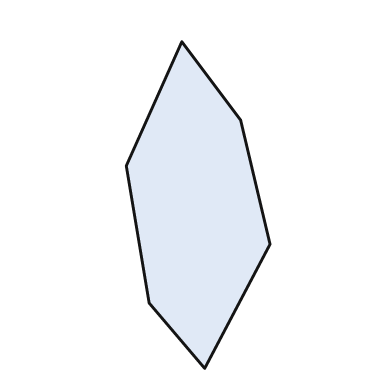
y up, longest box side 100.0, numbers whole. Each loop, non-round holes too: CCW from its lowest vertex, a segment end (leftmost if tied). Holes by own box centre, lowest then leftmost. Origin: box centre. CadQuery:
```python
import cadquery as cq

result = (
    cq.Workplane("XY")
    .moveTo(2.0, -50.0)
    .lineTo(22.0, -12.0)
    .lineTo(13.0, 26.0)
    .lineTo(-5.0, 50.0)
    .lineTo(-22.0, 12.0)
    .lineTo(-15.0, -30.0)
    .close()
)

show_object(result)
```